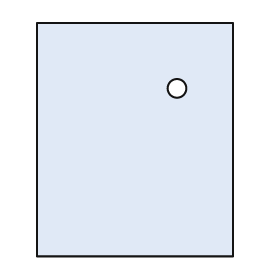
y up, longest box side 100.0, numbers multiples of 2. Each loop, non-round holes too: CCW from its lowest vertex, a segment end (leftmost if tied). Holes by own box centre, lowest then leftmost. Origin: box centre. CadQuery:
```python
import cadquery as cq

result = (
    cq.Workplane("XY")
    .moveTo(-42.0, -50.0)
    .lineTo(42.0, -50.0)
    .lineTo(42.0, 50.0)
    .lineTo(-42.0, 50.0)
    .close()
    .moveTo(18.0, 22.0)
    .circle(4.0)
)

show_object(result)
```